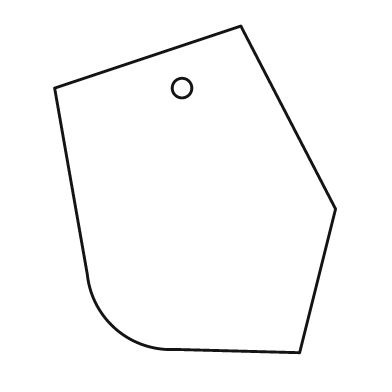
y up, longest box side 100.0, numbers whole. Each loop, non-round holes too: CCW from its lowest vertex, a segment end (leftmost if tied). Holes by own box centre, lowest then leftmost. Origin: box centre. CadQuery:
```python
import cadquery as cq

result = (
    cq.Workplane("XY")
    .moveTo(32.0, -50.0)
    .lineTo(43.0, -6.0)
    .lineTo(14.0, 50.0)
    .lineTo(-43.0, 31.0)
    .lineTo(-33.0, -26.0)
    .threePointArc((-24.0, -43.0), (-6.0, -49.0))
    .close()
    .moveTo(-4.0, 31.0)
    .circle(3.0)
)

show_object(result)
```